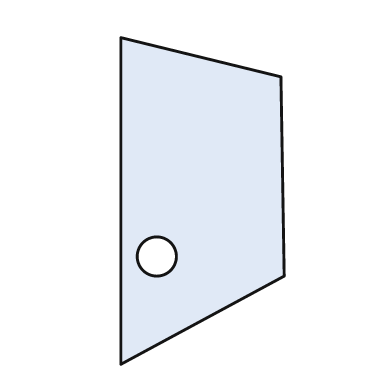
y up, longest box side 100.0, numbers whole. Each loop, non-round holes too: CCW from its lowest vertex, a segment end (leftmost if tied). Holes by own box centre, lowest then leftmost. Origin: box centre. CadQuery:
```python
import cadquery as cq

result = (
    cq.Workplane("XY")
    .moveTo(-25.0, -50.0)
    .lineTo(25.0, -23.0)
    .lineTo(24.0, 38.0)
    .lineTo(-25.0, 50.0)
    .close()
    .moveTo(-14.0, -17.0)
    .circle(6.0)
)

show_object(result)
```